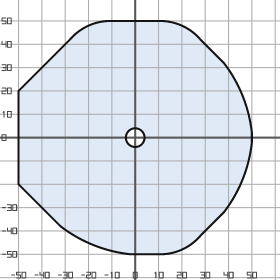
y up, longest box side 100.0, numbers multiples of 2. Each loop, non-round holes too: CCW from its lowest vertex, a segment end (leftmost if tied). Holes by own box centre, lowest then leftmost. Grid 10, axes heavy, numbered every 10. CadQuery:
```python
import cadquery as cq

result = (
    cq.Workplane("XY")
    .moveTo(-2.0, -50.0)
    .lineTo(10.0, -50.0)
    .threePointArc((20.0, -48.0), (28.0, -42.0))
    .lineTo(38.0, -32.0)
    .threePointArc((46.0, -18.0), (50.0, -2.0))
    .lineTo(50.0, 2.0)
    .threePointArc((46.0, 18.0), (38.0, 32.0))
    .lineTo(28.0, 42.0)
    .threePointArc((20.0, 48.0), (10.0, 50.0))
    .lineTo(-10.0, 50.0)
    .threePointArc((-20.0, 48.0), (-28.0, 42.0))
    .lineTo(-50.0, 20.0)
    .lineTo(-50.0, -20.0)
    .lineTo(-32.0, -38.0)
    .threePointArc((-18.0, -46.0), (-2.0, -50.0))
    .close()
    .moveTo(0.0, 0.0)
    .circle(4.0)
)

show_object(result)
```